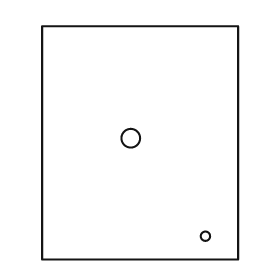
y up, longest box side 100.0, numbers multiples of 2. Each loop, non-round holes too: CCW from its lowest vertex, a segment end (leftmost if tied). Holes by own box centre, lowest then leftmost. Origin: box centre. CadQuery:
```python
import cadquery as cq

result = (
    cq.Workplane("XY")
    .moveTo(-42.0, -50.0)
    .lineTo(42.0, -50.0)
    .lineTo(42.0, 50.0)
    .lineTo(-42.0, 50.0)
    .close()
    .moveTo(28.0, -40.0)
    .circle(2.0)
    .moveTo(-4.0, 2.0)
    .circle(4.0)
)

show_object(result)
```